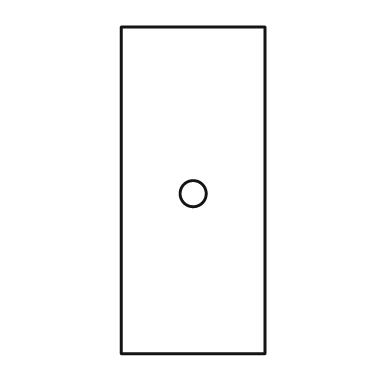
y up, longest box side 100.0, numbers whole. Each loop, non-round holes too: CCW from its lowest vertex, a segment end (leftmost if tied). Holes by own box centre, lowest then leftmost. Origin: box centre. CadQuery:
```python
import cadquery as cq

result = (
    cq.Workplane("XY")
    .moveTo(-22.0, -50.0)
    .lineTo(22.0, -50.0)
    .lineTo(22.0, 50.0)
    .lineTo(-22.0, 50.0)
    .close()
    .moveTo(0.0, -1.0)
    .circle(4.0)
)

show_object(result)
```